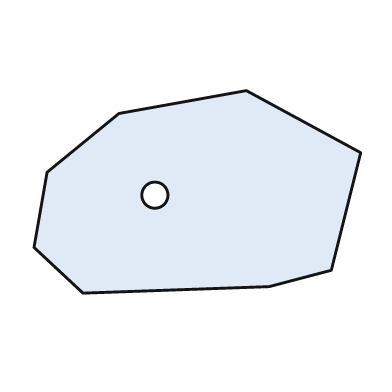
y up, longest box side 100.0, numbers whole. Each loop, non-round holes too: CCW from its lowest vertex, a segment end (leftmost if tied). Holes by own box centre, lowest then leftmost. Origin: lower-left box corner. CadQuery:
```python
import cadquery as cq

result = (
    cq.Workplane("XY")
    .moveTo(15.0, 0.0)
    .lineTo(72.0, 2.0)
    .lineTo(91.0, 7.0)
    .lineTo(100.0, 43.0)
    .lineTo(65.0, 62.0)
    .lineTo(26.0, 55.0)
    .lineTo(4.0, 37.0)
    .lineTo(0.0, 14.0)
    .close()
    .moveTo(37.0, 30.0)
    .circle(4.0)
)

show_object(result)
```